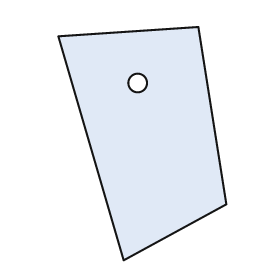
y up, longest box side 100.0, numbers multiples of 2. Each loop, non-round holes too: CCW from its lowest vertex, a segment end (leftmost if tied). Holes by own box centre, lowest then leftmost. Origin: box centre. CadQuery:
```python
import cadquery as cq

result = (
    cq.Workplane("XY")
    .moveTo(-8.0, -50.0)
    .lineTo(36.0, -26.0)
    .lineTo(24.0, 50.0)
    .lineTo(-36.0, 46.0)
    .close()
    .moveTo(-2.0, 26.0)
    .circle(4.0)
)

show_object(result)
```